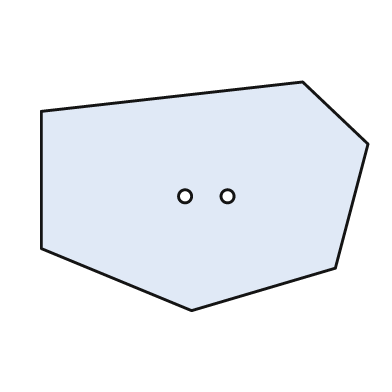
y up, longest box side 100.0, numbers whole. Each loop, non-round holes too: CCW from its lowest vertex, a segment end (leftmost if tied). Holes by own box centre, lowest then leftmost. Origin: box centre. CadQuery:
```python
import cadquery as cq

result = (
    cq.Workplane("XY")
    .moveTo(-4.0, -35.0)
    .lineTo(40.0, -22.0)
    .lineTo(50.0, 16.0)
    .lineTo(30.0, 35.0)
    .lineTo(-50.0, 26.0)
    .lineTo(-50.0, -16.0)
    .close()
    .moveTo(-6.0, 0.0)
    .circle(2.0)
    .moveTo(7.0, 0.0)
    .circle(2.0)
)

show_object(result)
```